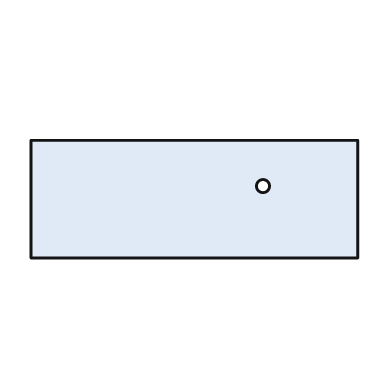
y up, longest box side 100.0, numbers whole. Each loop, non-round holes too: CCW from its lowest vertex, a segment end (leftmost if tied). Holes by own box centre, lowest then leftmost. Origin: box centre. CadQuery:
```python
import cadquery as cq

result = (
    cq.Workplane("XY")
    .moveTo(-50.0, -18.0)
    .lineTo(50.0, -18.0)
    .lineTo(50.0, 18.0)
    .lineTo(-50.0, 18.0)
    .close()
    .moveTo(21.0, 4.0)
    .circle(2.0)
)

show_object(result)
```